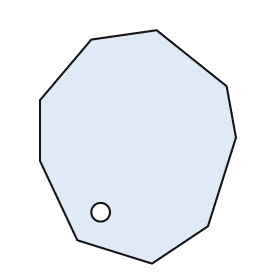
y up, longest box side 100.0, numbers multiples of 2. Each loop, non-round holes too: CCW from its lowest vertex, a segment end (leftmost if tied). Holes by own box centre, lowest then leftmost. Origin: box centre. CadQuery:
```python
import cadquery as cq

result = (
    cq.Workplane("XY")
    .moveTo(6.0, -50.0)
    .lineTo(30.0, -34.0)
    .lineTo(42.0, 4.0)
    .lineTo(38.0, 26.0)
    .lineTo(8.0, 50.0)
    .lineTo(-20.0, 46.0)
    .lineTo(-42.0, 20.0)
    .lineTo(-42.0, -6.0)
    .lineTo(-26.0, -40.0)
    .close()
    .moveTo(-16.0, -28.0)
    .circle(4.0)
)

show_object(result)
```